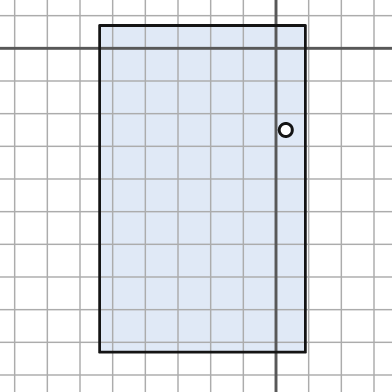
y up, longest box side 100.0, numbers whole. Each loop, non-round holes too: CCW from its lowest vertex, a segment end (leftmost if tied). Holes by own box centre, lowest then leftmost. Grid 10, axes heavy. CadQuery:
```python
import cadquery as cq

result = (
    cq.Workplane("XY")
    .moveTo(-54.0, -93.0)
    .lineTo(9.0, -93.0)
    .lineTo(9.0, 7.0)
    .lineTo(-54.0, 7.0)
    .close()
    .moveTo(3.0, -25.0)
    .circle(2.0)
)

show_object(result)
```